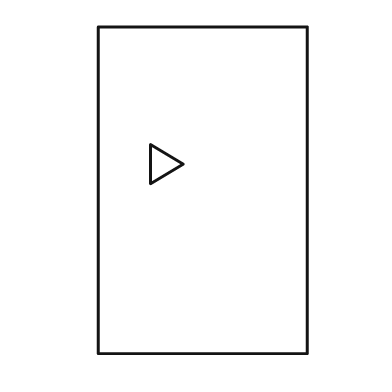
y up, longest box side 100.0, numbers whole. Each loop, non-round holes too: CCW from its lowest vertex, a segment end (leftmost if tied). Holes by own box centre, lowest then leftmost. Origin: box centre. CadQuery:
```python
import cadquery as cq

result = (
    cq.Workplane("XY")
    .moveTo(-32.0, -50.0)
    .lineTo(32.0, -50.0)
    .lineTo(32.0, 50.0)
    .lineTo(-32.0, 50.0)
    .close()
    .moveTo(-16.0, 2.0)
    .lineTo(-6.0, 8.0)
    .lineTo(-16.0, 14.0)
    .close()
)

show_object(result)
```